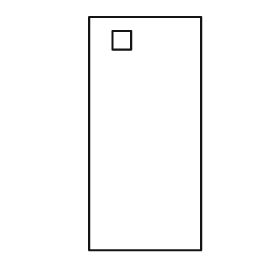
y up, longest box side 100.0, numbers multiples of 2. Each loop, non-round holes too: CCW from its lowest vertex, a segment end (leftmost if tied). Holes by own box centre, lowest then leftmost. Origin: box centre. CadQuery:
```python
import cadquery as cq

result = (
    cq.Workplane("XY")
    .moveTo(-24.0, -50.0)
    .lineTo(24.0, -50.0)
    .lineTo(24.0, 50.0)
    .lineTo(-24.0, 50.0)
    .close()
    .moveTo(-14.0, 36.0)
    .lineTo(-6.0, 36.0)
    .lineTo(-6.0, 44.0)
    .lineTo(-14.0, 44.0)
    .close()
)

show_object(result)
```